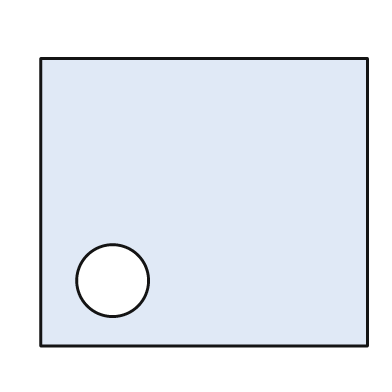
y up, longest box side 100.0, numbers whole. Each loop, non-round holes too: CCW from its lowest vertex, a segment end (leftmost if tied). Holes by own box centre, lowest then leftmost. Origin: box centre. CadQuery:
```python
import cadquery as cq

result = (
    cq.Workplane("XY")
    .moveTo(-50.0, -44.0)
    .lineTo(50.0, -44.0)
    .lineTo(50.0, 44.0)
    .lineTo(-50.0, 44.0)
    .close()
    .moveTo(-28.0, -24.0)
    .circle(11.0)
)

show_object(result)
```